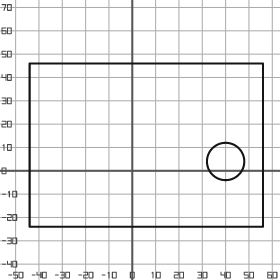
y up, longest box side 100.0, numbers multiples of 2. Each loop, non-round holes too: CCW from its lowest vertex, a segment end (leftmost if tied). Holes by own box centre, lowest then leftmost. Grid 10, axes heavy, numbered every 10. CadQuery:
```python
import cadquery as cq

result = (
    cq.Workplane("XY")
    .moveTo(-44.0, -24.0)
    .lineTo(56.0, -24.0)
    .lineTo(56.0, 46.0)
    .lineTo(-44.0, 46.0)
    .close()
    .moveTo(40.0, 4.0)
    .circle(8.0)
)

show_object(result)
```